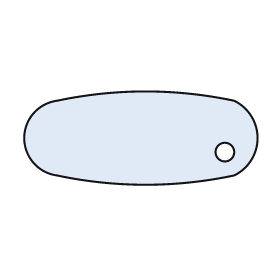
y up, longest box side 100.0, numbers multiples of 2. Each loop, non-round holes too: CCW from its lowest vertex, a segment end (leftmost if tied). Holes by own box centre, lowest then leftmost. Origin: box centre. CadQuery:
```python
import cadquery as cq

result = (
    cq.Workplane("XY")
    .moveTo(-36.0, -16.0)
    .threePointArc((2.0, -20.0), (40.0, -16.0))
    .threePointArc((50.0, 0.0), (40.0, 16.0))
    .threePointArc((2.0, 20.0), (-36.0, 16.0))
    .threePointArc((-50.0, 0.0), (-36.0, -16.0))
    .close()
    .moveTo(36.0, -6.0)
    .circle(4.0)
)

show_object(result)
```